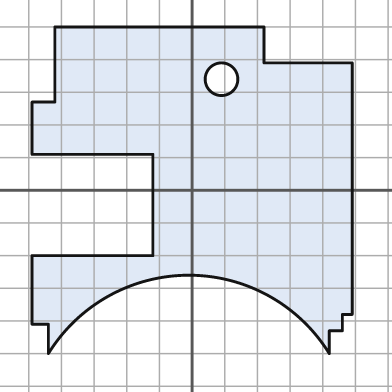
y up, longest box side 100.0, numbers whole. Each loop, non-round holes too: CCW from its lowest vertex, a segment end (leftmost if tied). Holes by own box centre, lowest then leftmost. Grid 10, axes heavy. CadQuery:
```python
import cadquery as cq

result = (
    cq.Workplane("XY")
    .moveTo(-44.0, -50.0)
    .threePointArc((-1.0, -26.0), (42.0, -50.0))
    .lineTo(42.0, -43.0)
    .lineTo(46.0, -43.0)
    .lineTo(46.0, -38.0)
    .lineTo(49.0, -38.0)
    .lineTo(49.0, 39.0)
    .lineTo(22.0, 39.0)
    .lineTo(22.0, 50.0)
    .lineTo(-42.0, 50.0)
    .lineTo(-42.0, 27.0)
    .lineTo(-49.0, 27.0)
    .lineTo(-49.0, 11.0)
    .lineTo(-12.0, 11.0)
    .lineTo(-12.0, -20.0)
    .lineTo(-49.0, -20.0)
    .lineTo(-49.0, -41.0)
    .lineTo(-44.0, -41.0)
    .close()
    .moveTo(9.0, 34.0)
    .circle(5.0)
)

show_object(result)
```